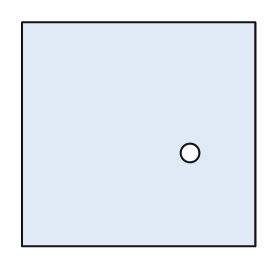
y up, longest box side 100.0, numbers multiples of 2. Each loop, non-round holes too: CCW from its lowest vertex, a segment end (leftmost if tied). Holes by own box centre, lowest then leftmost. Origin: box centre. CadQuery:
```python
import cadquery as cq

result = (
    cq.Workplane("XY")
    .moveTo(-50.0, -48.0)
    .lineTo(50.0, -48.0)
    .lineTo(50.0, 48.0)
    .lineTo(-50.0, 48.0)
    .close()
    .moveTo(22.0, -8.0)
    .circle(4.0)
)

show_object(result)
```